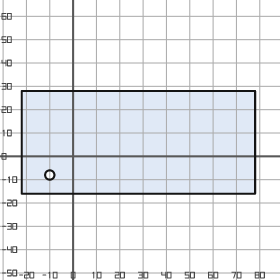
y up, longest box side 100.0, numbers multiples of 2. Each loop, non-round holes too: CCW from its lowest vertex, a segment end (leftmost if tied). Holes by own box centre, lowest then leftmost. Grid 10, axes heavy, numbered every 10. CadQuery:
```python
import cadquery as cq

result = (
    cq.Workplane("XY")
    .moveTo(-22.0, -16.0)
    .lineTo(78.0, -16.0)
    .lineTo(78.0, 28.0)
    .lineTo(-22.0, 28.0)
    .close()
    .moveTo(-10.0, -8.0)
    .circle(2.0)
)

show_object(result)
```